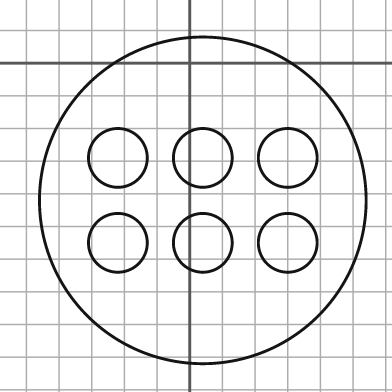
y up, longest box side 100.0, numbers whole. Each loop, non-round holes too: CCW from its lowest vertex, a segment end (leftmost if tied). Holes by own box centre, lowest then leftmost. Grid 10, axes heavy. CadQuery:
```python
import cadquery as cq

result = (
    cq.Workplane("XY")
    .moveTo(4.0, -42.0)
    .circle(50.0)
    .moveTo(-22.0, -55.0)
    .circle(9.0)
    .moveTo(4.0, -55.0)
    .circle(9.0)
    .moveTo(30.0, -55.0)
    .circle(9.0)
    .moveTo(-22.0, -29.0)
    .circle(9.0)
    .moveTo(4.0, -29.0)
    .circle(9.0)
    .moveTo(30.0, -29.0)
    .circle(9.0)
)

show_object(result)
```